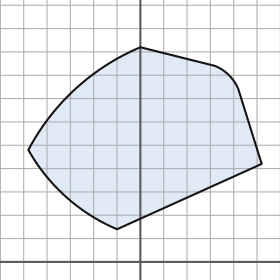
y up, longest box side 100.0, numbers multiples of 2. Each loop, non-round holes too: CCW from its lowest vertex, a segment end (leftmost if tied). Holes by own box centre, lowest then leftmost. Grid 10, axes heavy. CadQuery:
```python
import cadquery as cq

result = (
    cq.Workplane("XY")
    .moveTo(-10.0, 14.0)
    .lineTo(52.0, 42.0)
    .lineTo(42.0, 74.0)
    .threePointArc((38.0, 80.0), (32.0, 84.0))
    .lineTo(0.0, 92.0)
    .threePointArc((-28.0, 74.0), (-48.0, 48.0))
    .threePointArc((-32.0, 28.0), (-10.0, 14.0))
    .close()
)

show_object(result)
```